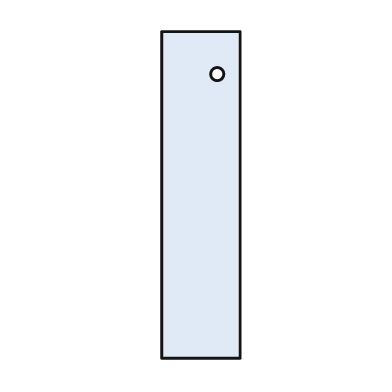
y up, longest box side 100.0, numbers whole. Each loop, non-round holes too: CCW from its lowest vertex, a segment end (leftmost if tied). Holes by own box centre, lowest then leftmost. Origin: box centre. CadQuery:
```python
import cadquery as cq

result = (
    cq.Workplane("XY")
    .moveTo(-12.0, -50.0)
    .lineTo(12.0, -50.0)
    .lineTo(12.0, 50.0)
    .lineTo(-12.0, 50.0)
    .close()
    .moveTo(5.0, 37.0)
    .circle(2.0)
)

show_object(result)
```